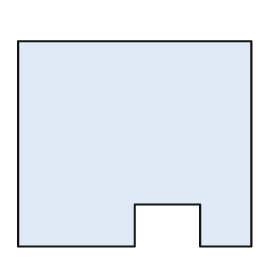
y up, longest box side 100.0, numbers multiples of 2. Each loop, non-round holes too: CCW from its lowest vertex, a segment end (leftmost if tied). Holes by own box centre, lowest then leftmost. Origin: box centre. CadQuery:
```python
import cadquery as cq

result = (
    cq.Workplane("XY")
    .moveTo(-50.0, -44.0)
    .lineTo(0.0, -44.0)
    .lineTo(0.0, -26.0)
    .lineTo(28.0, -26.0)
    .lineTo(28.0, -44.0)
    .lineTo(50.0, -44.0)
    .lineTo(50.0, 44.0)
    .lineTo(-50.0, 44.0)
    .close()
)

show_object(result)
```